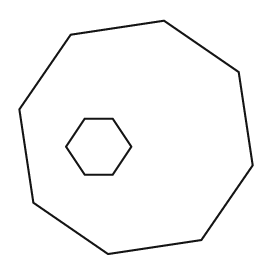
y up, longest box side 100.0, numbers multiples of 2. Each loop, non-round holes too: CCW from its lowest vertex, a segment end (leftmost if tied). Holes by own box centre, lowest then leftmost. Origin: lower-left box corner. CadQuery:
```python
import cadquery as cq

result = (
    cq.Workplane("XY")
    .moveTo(38.0, 0.0)
    .lineTo(78.0, 6.0)
    .lineTo(100.0, 38.0)
    .lineTo(94.0, 78.0)
    .lineTo(62.0, 100.0)
    .lineTo(22.0, 94.0)
    .lineTo(0.0, 62.0)
    .lineTo(6.0, 22.0)
    .close()
    .moveTo(28.0, 34.0)
    .lineTo(40.0, 34.0)
    .lineTo(48.0, 46.0)
    .lineTo(40.0, 58.0)
    .lineTo(28.0, 58.0)
    .lineTo(20.0, 46.0)
    .close()
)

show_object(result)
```